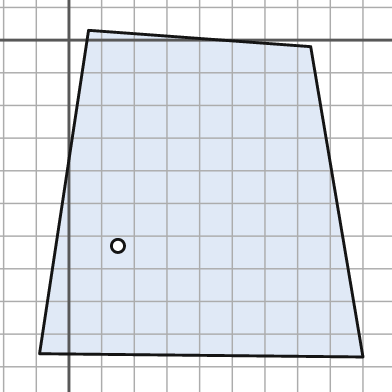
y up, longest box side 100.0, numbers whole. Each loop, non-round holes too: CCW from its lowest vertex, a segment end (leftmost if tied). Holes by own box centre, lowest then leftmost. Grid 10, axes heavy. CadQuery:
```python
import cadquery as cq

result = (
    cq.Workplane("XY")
    .moveTo(90.0, -97.0)
    .lineTo(74.0, -2.0)
    .lineTo(6.0, 3.0)
    .lineTo(-9.0, -96.0)
    .close()
    .moveTo(15.0, -63.0)
    .circle(2.0)
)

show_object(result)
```